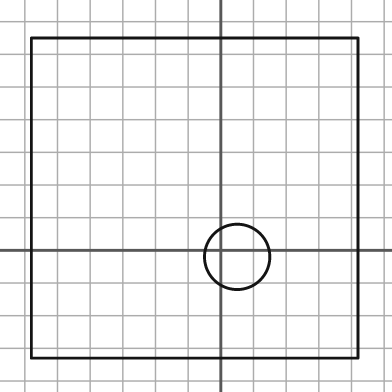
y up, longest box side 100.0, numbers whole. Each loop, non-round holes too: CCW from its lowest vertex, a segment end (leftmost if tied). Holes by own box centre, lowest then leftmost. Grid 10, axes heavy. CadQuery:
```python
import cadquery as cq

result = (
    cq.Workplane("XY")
    .moveTo(-58.0, -33.0)
    .lineTo(42.0, -33.0)
    .lineTo(42.0, 65.0)
    .lineTo(-58.0, 65.0)
    .close()
    .moveTo(5.0, -2.0)
    .circle(10.0)
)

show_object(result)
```